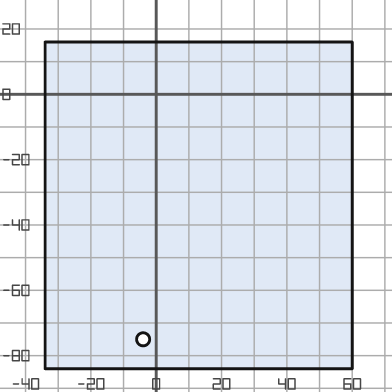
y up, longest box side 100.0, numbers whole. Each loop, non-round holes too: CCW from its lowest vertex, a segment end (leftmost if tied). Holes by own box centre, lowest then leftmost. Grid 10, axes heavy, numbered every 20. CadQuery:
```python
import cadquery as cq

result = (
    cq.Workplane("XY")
    .moveTo(-34.0, -84.0)
    .lineTo(60.0, -84.0)
    .lineTo(60.0, 16.0)
    .lineTo(-34.0, 16.0)
    .close()
    .moveTo(-4.0, -75.0)
    .circle(2.0)
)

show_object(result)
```